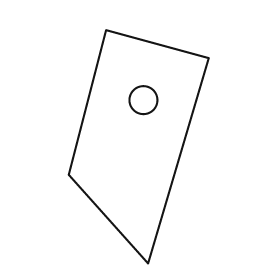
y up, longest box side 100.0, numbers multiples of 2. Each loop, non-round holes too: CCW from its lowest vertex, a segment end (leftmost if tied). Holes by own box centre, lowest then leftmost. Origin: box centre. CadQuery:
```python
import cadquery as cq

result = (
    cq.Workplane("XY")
    .moveTo(4.0, -50.0)
    .lineTo(30.0, 38.0)
    .lineTo(-14.0, 50.0)
    .lineTo(-30.0, -12.0)
    .close()
    .moveTo(2.0, 20.0)
    .circle(6.0)
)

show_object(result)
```